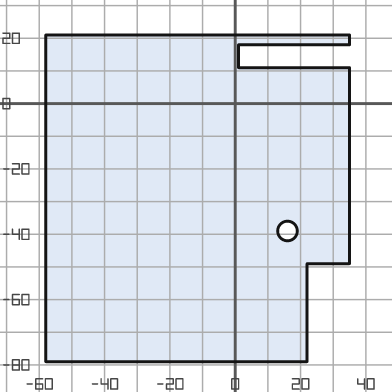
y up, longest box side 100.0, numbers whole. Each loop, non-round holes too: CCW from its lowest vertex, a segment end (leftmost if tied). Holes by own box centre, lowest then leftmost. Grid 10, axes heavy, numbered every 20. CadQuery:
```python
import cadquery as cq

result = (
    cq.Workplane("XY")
    .moveTo(-58.0, -79.0)
    .lineTo(22.0, -79.0)
    .lineTo(22.0, -49.0)
    .lineTo(35.0, -49.0)
    .lineTo(35.0, 11.0)
    .lineTo(1.0, 11.0)
    .lineTo(1.0, 18.0)
    .lineTo(35.0, 18.0)
    .lineTo(35.0, 21.0)
    .lineTo(-58.0, 21.0)
    .close()
    .moveTo(16.0, -39.0)
    .circle(3.0)
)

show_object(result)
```